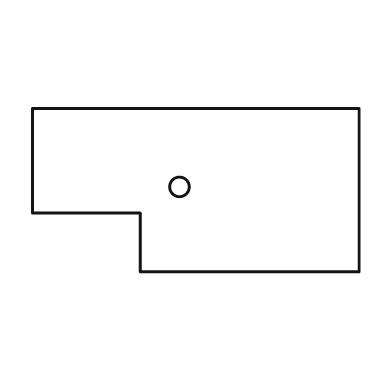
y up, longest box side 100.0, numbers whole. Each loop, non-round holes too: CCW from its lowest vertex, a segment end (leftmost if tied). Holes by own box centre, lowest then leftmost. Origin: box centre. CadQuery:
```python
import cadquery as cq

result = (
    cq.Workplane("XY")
    .moveTo(-17.0, -25.0)
    .lineTo(50.0, -25.0)
    .lineTo(50.0, 25.0)
    .lineTo(-50.0, 25.0)
    .lineTo(-50.0, -7.0)
    .lineTo(-17.0, -7.0)
    .close()
    .moveTo(-5.0, 1.0)
    .circle(3.0)
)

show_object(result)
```